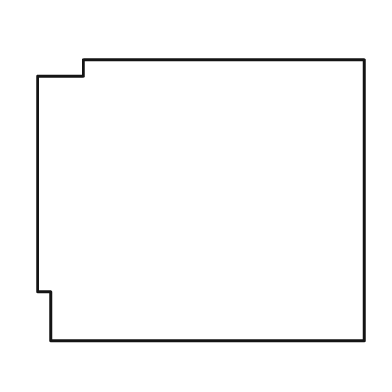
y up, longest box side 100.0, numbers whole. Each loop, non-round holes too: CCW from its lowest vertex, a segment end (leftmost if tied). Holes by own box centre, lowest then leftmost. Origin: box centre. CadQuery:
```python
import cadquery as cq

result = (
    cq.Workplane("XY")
    .moveTo(-46.0, -43.0)
    .lineTo(50.0, -43.0)
    .lineTo(50.0, 43.0)
    .lineTo(-36.0, 43.0)
    .lineTo(-36.0, 38.0)
    .lineTo(-50.0, 38.0)
    .lineTo(-50.0, -28.0)
    .lineTo(-46.0, -28.0)
    .close()
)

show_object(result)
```